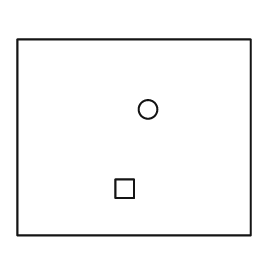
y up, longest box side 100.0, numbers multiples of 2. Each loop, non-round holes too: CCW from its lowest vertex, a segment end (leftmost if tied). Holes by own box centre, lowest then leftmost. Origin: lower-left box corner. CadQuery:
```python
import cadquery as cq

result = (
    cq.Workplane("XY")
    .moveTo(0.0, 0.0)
    .lineTo(100.0, 0.0)
    .lineTo(100.0, 84.0)
    .lineTo(0.0, 84.0)
    .close()
    .moveTo(42.0, 16.0)
    .lineTo(50.0, 16.0)
    .lineTo(50.0, 24.0)
    .lineTo(42.0, 24.0)
    .close()
    .moveTo(56.0, 54.0)
    .circle(4.0)
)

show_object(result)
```